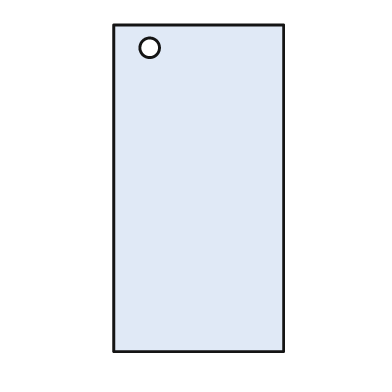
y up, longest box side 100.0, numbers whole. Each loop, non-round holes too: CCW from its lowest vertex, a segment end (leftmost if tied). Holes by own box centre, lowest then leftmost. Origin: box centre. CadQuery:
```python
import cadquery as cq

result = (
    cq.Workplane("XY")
    .moveTo(-26.0, -50.0)
    .lineTo(26.0, -50.0)
    .lineTo(26.0, 50.0)
    .lineTo(-26.0, 50.0)
    .close()
    .moveTo(-15.0, 43.0)
    .circle(3.0)
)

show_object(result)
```